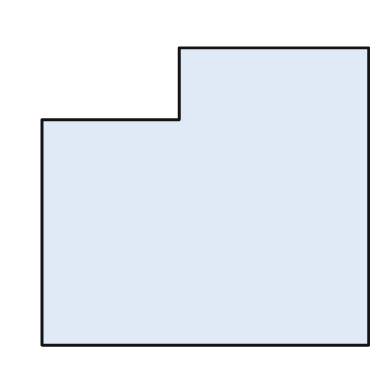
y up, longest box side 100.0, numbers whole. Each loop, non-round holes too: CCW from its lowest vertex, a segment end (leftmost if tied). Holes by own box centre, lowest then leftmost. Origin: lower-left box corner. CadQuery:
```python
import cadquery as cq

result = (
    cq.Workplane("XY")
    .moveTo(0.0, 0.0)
    .lineTo(100.0, 0.0)
    .lineTo(100.0, 91.0)
    .lineTo(42.0, 91.0)
    .lineTo(42.0, 69.0)
    .lineTo(0.0, 69.0)
    .close()
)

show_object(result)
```